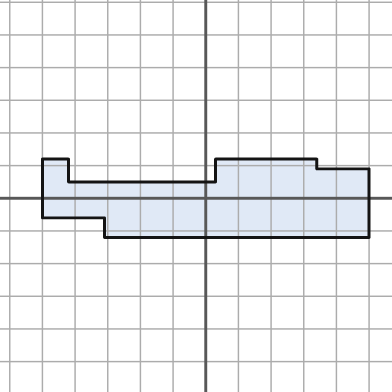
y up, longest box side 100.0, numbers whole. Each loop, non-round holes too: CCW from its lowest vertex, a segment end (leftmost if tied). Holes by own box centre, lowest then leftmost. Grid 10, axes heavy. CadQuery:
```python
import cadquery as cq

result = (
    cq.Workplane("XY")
    .moveTo(-31.0, -12.0)
    .lineTo(50.0, -12.0)
    .lineTo(50.0, 9.0)
    .lineTo(34.0, 9.0)
    .lineTo(34.0, 12.0)
    .lineTo(3.0, 12.0)
    .lineTo(3.0, 5.0)
    .lineTo(-42.0, 5.0)
    .lineTo(-42.0, 12.0)
    .lineTo(-50.0, 12.0)
    .lineTo(-50.0, -6.0)
    .lineTo(-31.0, -6.0)
    .close()
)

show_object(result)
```